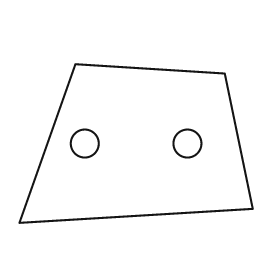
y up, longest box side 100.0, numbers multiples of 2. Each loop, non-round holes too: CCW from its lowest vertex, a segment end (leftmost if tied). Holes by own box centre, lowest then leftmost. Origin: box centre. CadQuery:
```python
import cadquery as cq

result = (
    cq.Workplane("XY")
    .moveTo(-50.0, -34.0)
    .lineTo(50.0, -28.0)
    .lineTo(38.0, 30.0)
    .lineTo(-26.0, 34.0)
    .close()
    .moveTo(-22.0, 0.0)
    .circle(6.0)
    .moveTo(22.0, 0.0)
    .circle(6.0)
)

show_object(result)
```